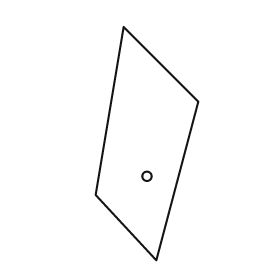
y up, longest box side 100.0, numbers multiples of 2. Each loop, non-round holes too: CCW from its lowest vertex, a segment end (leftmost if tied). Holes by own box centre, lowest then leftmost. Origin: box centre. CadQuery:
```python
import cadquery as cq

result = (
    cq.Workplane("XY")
    .moveTo(4.0, -50.0)
    .lineTo(22.0, 18.0)
    .lineTo(-10.0, 50.0)
    .lineTo(-22.0, -22.0)
    .close()
    .moveTo(0.0, -14.0)
    .circle(2.0)
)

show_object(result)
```